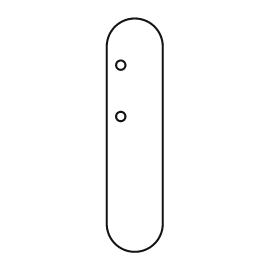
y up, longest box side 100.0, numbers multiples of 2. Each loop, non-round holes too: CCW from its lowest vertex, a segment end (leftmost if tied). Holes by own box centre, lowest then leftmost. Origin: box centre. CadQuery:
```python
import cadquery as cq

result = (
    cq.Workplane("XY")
    .moveTo(-12.0, -38.0)
    .threePointArc((0.0, -50.0), (12.0, -38.0))
    .lineTo(12.0, 38.0)
    .threePointArc((0.0, 50.0), (-12.0, 38.0))
    .close()
    .moveTo(-6.0, 8.0)
    .circle(2.0)
    .moveTo(-6.0, 30.0)
    .circle(2.0)
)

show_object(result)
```